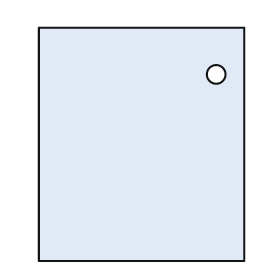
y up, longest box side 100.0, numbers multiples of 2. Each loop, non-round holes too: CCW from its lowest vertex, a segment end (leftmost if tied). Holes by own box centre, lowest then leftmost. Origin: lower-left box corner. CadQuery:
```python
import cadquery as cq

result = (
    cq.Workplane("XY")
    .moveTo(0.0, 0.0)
    .lineTo(88.0, 0.0)
    .lineTo(88.0, 100.0)
    .lineTo(0.0, 100.0)
    .close()
    .moveTo(76.0, 80.0)
    .circle(4.0)
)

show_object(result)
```